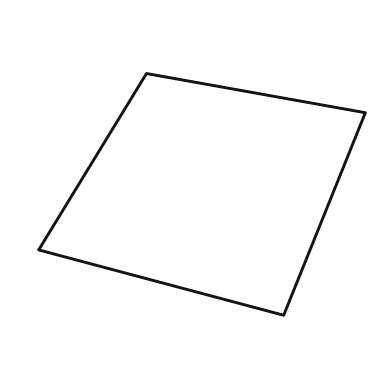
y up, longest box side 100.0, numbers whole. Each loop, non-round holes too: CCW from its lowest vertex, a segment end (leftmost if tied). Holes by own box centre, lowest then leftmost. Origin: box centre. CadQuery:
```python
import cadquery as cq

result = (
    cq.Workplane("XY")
    .moveTo(25.0, -37.0)
    .lineTo(50.0, 25.0)
    .lineTo(-17.0, 37.0)
    .lineTo(-50.0, -17.0)
    .close()
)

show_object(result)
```